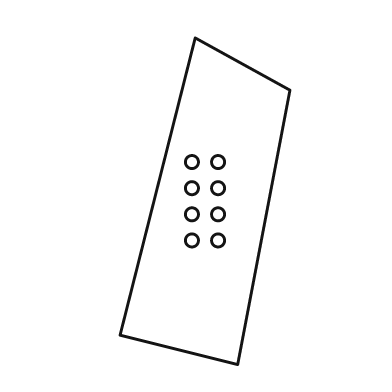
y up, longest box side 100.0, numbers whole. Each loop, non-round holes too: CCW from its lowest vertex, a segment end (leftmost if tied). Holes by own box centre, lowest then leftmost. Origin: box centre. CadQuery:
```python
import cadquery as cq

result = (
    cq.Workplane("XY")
    .moveTo(10.0, -50.0)
    .lineTo(26.0, 34.0)
    .lineTo(-3.0, 50.0)
    .lineTo(-26.0, -41.0)
    .close()
    .moveTo(-4.0, -12.0)
    .circle(2.0)
    .moveTo(4.0, -12.0)
    .circle(2.0)
    .moveTo(-4.0, -4.0)
    .circle(2.0)
    .moveTo(4.0, -4.0)
    .circle(2.0)
    .moveTo(-4.0, 4.0)
    .circle(2.0)
    .moveTo(4.0, 4.0)
    .circle(2.0)
    .moveTo(-4.0, 12.0)
    .circle(2.0)
    .moveTo(4.0, 12.0)
    .circle(2.0)
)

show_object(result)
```